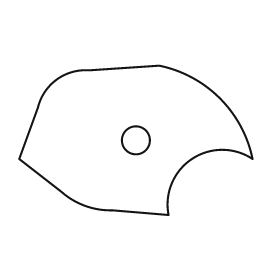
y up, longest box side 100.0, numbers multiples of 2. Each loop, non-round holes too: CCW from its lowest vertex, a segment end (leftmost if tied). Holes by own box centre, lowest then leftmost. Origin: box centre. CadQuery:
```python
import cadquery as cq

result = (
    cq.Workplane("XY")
    .moveTo(14.0, -32.0)
    .threePointArc((24.0, -8.0), (50.0, -8.0))
    .threePointArc((36.0, 18.0), (10.0, 32.0))
    .lineTo(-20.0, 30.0)
    .threePointArc((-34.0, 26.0), (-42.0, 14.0))
    .lineTo(-50.0, -8.0)
    .lineTo(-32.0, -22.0)
    .threePointArc((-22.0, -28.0), (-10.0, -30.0))
    .close()
    .moveTo(0.0, 0.0)
    .circle(6.0)
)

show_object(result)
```